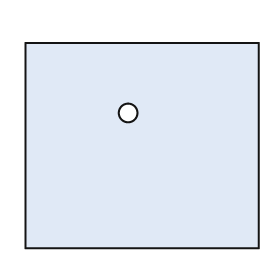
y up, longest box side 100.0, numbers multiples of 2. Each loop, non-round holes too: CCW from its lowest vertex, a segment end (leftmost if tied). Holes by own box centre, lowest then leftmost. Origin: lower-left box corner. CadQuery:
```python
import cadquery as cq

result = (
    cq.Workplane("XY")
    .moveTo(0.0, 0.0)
    .lineTo(100.0, 0.0)
    .lineTo(100.0, 88.0)
    .lineTo(0.0, 88.0)
    .close()
    .moveTo(44.0, 58.0)
    .circle(4.0)
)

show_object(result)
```